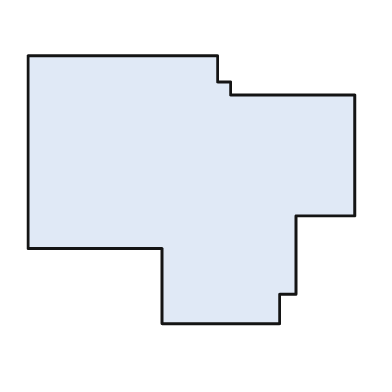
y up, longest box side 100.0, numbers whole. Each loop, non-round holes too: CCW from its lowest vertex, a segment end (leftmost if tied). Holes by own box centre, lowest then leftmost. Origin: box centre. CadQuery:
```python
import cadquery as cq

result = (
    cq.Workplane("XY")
    .moveTo(-9.0, -41.0)
    .lineTo(27.0, -41.0)
    .lineTo(27.0, -32.0)
    .lineTo(32.0, -32.0)
    .lineTo(32.0, -8.0)
    .lineTo(50.0, -8.0)
    .lineTo(50.0, 29.0)
    .lineTo(12.0, 29.0)
    .lineTo(12.0, 33.0)
    .lineTo(8.0, 33.0)
    .lineTo(8.0, 41.0)
    .lineTo(-50.0, 41.0)
    .lineTo(-50.0, -18.0)
    .lineTo(-9.0, -18.0)
    .close()
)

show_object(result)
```